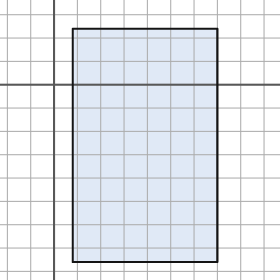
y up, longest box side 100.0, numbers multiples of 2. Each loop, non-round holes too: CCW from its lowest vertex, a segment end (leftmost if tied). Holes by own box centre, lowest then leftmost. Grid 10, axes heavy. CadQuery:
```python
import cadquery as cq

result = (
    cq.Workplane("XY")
    .moveTo(8.0, -76.0)
    .lineTo(70.0, -76.0)
    .lineTo(70.0, 24.0)
    .lineTo(8.0, 24.0)
    .close()
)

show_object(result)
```